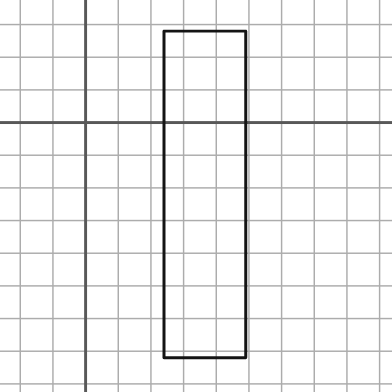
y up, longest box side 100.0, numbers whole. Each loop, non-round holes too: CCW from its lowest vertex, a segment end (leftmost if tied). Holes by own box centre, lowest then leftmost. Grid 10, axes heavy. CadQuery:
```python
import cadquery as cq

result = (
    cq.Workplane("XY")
    .moveTo(24.0, -72.0)
    .lineTo(49.0, -72.0)
    .lineTo(49.0, 28.0)
    .lineTo(24.0, 28.0)
    .close()
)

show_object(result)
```